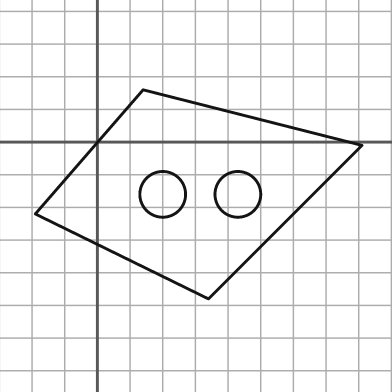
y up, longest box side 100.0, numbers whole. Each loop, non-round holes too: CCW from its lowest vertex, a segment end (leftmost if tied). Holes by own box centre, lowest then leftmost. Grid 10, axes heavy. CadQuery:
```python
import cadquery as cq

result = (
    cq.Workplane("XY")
    .moveTo(34.0, -48.0)
    .lineTo(81.0, -1.0)
    .lineTo(14.0, 16.0)
    .lineTo(-19.0, -22.0)
    .close()
    .moveTo(20.0, -16.0)
    .circle(7.0)
    .moveTo(43.0, -16.0)
    .circle(7.0)
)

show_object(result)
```